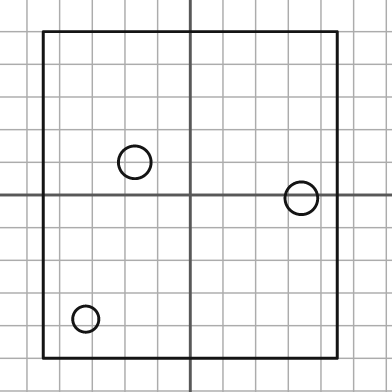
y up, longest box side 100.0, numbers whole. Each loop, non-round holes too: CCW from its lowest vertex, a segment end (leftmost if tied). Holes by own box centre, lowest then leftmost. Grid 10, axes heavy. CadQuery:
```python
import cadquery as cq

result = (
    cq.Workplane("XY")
    .moveTo(-45.0, -50.0)
    .lineTo(45.0, -50.0)
    .lineTo(45.0, 50.0)
    .lineTo(-45.0, 50.0)
    .close()
    .moveTo(-32.0, -38.0)
    .circle(4.0)
    .moveTo(34.0, -1.0)
    .circle(5.0)
    .moveTo(-17.0, 10.0)
    .circle(5.0)
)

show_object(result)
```